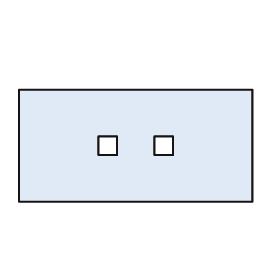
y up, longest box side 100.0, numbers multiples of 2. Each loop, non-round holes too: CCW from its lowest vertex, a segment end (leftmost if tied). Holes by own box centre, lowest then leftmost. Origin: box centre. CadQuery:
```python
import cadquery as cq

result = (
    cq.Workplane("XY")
    .moveTo(-50.0, -24.0)
    .lineTo(50.0, -24.0)
    .lineTo(50.0, 24.0)
    .lineTo(-50.0, 24.0)
    .close()
    .moveTo(-16.0, -4.0)
    .lineTo(-8.0, -4.0)
    .lineTo(-8.0, 4.0)
    .lineTo(-16.0, 4.0)
    .close()
    .moveTo(8.0, -4.0)
    .lineTo(16.0, -4.0)
    .lineTo(16.0, 4.0)
    .lineTo(8.0, 4.0)
    .close()
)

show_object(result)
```